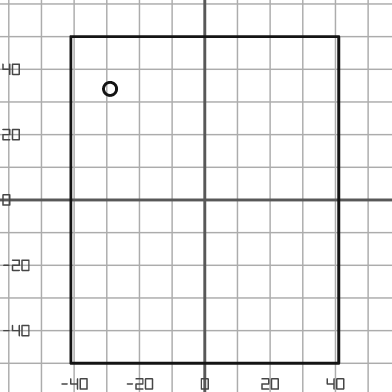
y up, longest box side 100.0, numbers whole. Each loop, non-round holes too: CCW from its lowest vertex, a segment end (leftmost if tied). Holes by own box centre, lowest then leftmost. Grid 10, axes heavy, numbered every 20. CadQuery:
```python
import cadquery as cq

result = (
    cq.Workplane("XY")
    .moveTo(-41.0, -50.0)
    .lineTo(41.0, -50.0)
    .lineTo(41.0, 50.0)
    .lineTo(-41.0, 50.0)
    .close()
    .moveTo(-29.0, 34.0)
    .circle(2.0)
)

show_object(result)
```